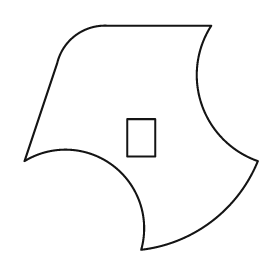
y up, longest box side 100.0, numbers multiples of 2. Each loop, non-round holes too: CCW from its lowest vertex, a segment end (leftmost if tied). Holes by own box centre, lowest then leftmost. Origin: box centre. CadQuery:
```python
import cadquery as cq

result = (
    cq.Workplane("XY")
    .moveTo(0.0, -48.0)
    .threePointArc((30.0, -36.0), (50.0, -10.0))
    .threePointArc((26.0, 14.0), (30.0, 48.0))
    .lineTo(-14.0, 48.0)
    .threePointArc((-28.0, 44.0), (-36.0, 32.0))
    .lineTo(-50.0, -10.0)
    .threePointArc((-12.0, -12.0), (0.0, -48.0))
    .close()
    .moveTo(-6.0, -8.0)
    .lineTo(6.0, -8.0)
    .lineTo(6.0, 8.0)
    .lineTo(-6.0, 8.0)
    .close()
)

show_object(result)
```